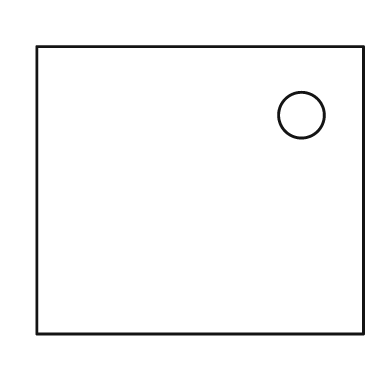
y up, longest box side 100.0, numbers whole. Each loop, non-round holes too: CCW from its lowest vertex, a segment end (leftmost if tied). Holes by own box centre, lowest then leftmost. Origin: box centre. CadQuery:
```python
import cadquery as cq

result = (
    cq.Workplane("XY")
    .moveTo(-50.0, -44.0)
    .lineTo(50.0, -44.0)
    .lineTo(50.0, 44.0)
    .lineTo(-50.0, 44.0)
    .close()
    .moveTo(31.0, 23.0)
    .circle(7.0)
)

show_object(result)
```